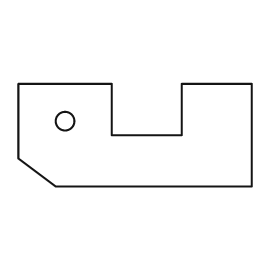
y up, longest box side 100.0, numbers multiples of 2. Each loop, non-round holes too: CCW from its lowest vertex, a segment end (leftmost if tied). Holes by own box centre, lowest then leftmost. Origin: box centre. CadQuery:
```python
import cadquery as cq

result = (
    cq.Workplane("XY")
    .moveTo(-34.0, -22.0)
    .lineTo(50.0, -22.0)
    .lineTo(50.0, 22.0)
    .lineTo(20.0, 22.0)
    .lineTo(20.0, 0.0)
    .lineTo(-10.0, 0.0)
    .lineTo(-10.0, 22.0)
    .lineTo(-50.0, 22.0)
    .lineTo(-50.0, -10.0)
    .close()
    .moveTo(-30.0, 6.0)
    .circle(4.0)
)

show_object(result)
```